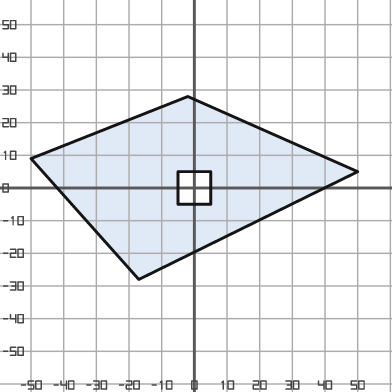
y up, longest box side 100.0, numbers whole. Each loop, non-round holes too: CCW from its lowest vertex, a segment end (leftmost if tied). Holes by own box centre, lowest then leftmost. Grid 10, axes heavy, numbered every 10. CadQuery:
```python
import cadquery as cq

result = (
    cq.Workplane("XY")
    .moveTo(-17.0, -28.0)
    .lineTo(50.0, 5.0)
    .lineTo(-2.0, 28.0)
    .lineTo(-50.0, 9.0)
    .close()
    .moveTo(-5.0, -5.0)
    .lineTo(5.0, -5.0)
    .lineTo(5.0, 5.0)
    .lineTo(-5.0, 5.0)
    .close()
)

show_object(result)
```